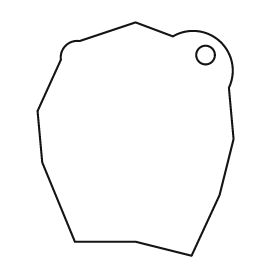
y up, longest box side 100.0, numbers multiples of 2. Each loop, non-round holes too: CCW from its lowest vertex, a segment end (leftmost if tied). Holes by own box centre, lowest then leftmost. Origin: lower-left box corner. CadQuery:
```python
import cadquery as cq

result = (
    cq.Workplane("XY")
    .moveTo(66.0, 0.0)
    .lineTo(78.0, 26.0)
    .lineTo(84.0, 50.0)
    .lineTo(82.0, 72.0)
    .threePointArc((78.0, 92.0), (58.0, 94.0))
    .lineTo(42.0, 100.0)
    .lineTo(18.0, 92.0)
    .threePointArc((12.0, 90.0), (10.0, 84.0))
    .lineTo(0.0, 62.0)
    .lineTo(2.0, 40.0)
    .lineTo(16.0, 6.0)
    .lineTo(42.0, 6.0)
    .close()
    .moveTo(72.0, 86.0)
    .circle(4.0)
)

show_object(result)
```